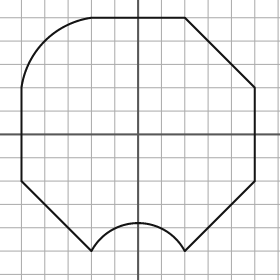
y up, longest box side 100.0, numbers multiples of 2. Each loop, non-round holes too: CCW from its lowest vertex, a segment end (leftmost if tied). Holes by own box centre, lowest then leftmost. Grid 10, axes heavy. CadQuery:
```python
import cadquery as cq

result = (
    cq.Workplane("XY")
    .moveTo(-20.0, -50.0)
    .threePointArc((0.0, -38.0), (20.0, -50.0))
    .lineTo(50.0, -20.0)
    .lineTo(50.0, 20.0)
    .lineTo(20.0, 50.0)
    .lineTo(-20.0, 50.0)
    .threePointArc((-40.0, 40.0), (-50.0, 20.0))
    .lineTo(-50.0, -20.0)
    .close()
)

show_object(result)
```